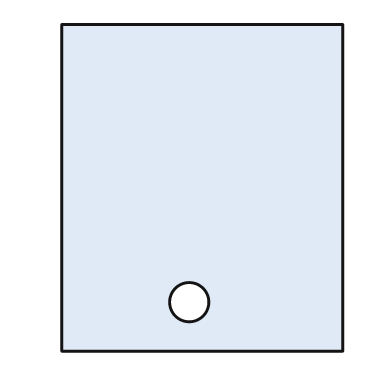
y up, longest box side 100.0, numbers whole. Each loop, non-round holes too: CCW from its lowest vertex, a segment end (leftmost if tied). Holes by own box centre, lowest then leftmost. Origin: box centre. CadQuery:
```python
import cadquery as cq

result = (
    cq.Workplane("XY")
    .moveTo(-43.0, -50.0)
    .lineTo(43.0, -50.0)
    .lineTo(43.0, 50.0)
    .lineTo(-43.0, 50.0)
    .close()
    .moveTo(-4.0, -35.0)
    .circle(6.0)
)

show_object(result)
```